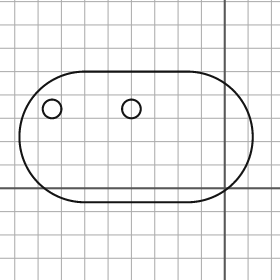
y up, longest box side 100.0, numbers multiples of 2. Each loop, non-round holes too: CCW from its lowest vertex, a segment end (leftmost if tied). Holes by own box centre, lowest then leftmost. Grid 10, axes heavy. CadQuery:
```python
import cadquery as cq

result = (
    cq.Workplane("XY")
    .moveTo(-60.0, -6.0)
    .lineTo(-16.0, -6.0)
    .threePointArc((12.0, 22.0), (-16.0, 50.0))
    .lineTo(-60.0, 50.0)
    .threePointArc((-88.0, 22.0), (-60.0, -6.0))
    .close()
    .moveTo(-74.0, 34.0)
    .circle(4.0)
    .moveTo(-40.0, 34.0)
    .circle(4.0)
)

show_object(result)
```